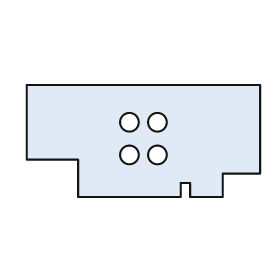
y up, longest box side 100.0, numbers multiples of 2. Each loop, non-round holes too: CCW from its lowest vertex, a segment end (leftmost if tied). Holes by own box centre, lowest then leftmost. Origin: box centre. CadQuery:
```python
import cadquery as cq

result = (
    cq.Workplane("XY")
    .moveTo(-28.0, -24.0)
    .lineTo(16.0, -24.0)
    .lineTo(16.0, -18.0)
    .lineTo(20.0, -18.0)
    .lineTo(20.0, -24.0)
    .lineTo(34.0, -24.0)
    .lineTo(34.0, -14.0)
    .lineTo(50.0, -14.0)
    .lineTo(50.0, 24.0)
    .lineTo(-50.0, 24.0)
    .lineTo(-50.0, -8.0)
    .lineTo(-28.0, -8.0)
    .close()
    .moveTo(-6.0, -6.0)
    .circle(4.0)
    .moveTo(6.0, -6.0)
    .circle(4.0)
    .moveTo(-6.0, 8.0)
    .circle(4.0)
    .moveTo(6.0, 8.0)
    .circle(4.0)
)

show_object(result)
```